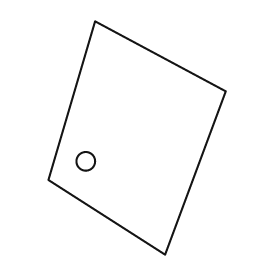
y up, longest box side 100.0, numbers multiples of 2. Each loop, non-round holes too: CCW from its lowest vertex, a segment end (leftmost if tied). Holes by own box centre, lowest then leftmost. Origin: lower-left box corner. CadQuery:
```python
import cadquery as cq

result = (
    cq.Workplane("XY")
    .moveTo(50.0, 0.0)
    .lineTo(76.0, 70.0)
    .lineTo(20.0, 100.0)
    .lineTo(0.0, 32.0)
    .close()
    .moveTo(16.0, 40.0)
    .circle(4.0)
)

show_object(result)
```